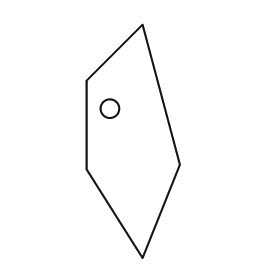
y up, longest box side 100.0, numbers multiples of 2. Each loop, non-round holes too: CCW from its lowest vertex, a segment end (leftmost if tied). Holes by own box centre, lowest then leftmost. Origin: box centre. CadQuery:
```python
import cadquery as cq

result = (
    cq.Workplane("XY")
    .moveTo(4.0, -50.0)
    .lineTo(20.0, -10.0)
    .lineTo(4.0, 50.0)
    .lineTo(-20.0, 26.0)
    .lineTo(-20.0, -12.0)
    .close()
    .moveTo(-10.0, 14.0)
    .circle(4.0)
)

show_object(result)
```